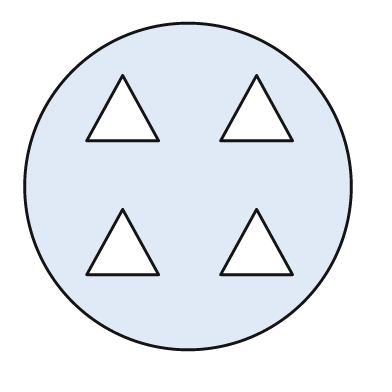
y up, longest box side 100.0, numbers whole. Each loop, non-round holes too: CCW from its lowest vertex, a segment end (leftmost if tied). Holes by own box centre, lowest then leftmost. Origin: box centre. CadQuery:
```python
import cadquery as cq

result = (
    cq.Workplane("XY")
    .moveTo(0.0, 0.0)
    .circle(50.0)
    .moveTo(-31.0, -27.0)
    .lineTo(-9.0, -27.0)
    .lineTo(-20.0, -7.0)
    .close()
    .moveTo(10.0, -27.0)
    .lineTo(32.0, -27.0)
    .lineTo(21.0, -7.0)
    .close()
    .moveTo(-31.0, 14.0)
    .lineTo(-9.0, 14.0)
    .lineTo(-20.0, 34.0)
    .close()
    .moveTo(10.0, 14.0)
    .lineTo(32.0, 14.0)
    .lineTo(21.0, 34.0)
    .close()
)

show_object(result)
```